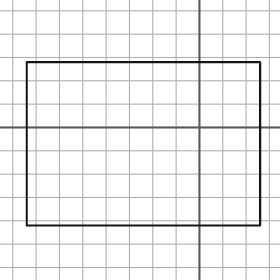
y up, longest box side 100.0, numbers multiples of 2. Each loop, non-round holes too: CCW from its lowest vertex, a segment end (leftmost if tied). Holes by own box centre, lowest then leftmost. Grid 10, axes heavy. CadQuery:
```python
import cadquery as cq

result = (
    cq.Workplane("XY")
    .moveTo(-74.0, -42.0)
    .lineTo(26.0, -42.0)
    .lineTo(26.0, 28.0)
    .lineTo(-74.0, 28.0)
    .close()
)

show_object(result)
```